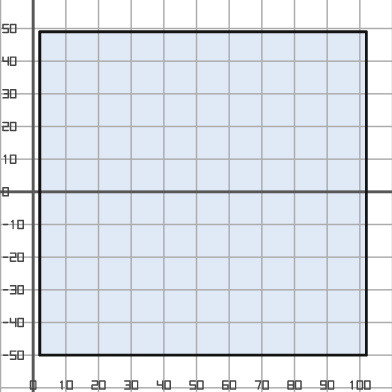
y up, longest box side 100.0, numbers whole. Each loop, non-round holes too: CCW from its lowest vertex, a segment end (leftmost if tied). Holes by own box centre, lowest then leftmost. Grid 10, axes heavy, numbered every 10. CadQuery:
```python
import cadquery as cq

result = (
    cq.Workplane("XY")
    .moveTo(2.0, -50.0)
    .lineTo(102.0, -50.0)
    .lineTo(102.0, 49.0)
    .lineTo(2.0, 49.0)
    .close()
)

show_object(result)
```